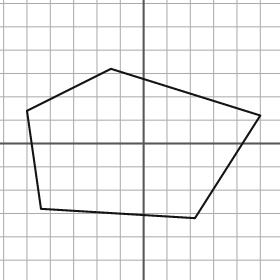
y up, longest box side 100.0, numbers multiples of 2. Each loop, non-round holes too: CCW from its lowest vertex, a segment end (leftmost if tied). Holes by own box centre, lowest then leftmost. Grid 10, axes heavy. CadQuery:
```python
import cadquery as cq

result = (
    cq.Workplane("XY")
    .moveTo(22.0, -32.0)
    .lineTo(50.0, 12.0)
    .lineTo(-14.0, 32.0)
    .lineTo(-50.0, 14.0)
    .lineTo(-44.0, -28.0)
    .close()
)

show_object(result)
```